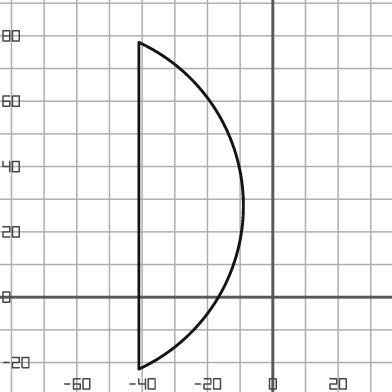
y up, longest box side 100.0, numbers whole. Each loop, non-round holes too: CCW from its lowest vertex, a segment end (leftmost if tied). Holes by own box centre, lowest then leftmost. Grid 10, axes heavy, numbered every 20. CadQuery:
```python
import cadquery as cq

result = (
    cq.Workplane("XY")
    .moveTo(-41.0, -22.0)
    .threePointArc((-9.0, 28.0), (-41.0, 78.0))
    .close()
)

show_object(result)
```